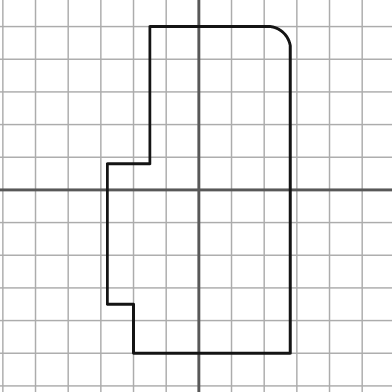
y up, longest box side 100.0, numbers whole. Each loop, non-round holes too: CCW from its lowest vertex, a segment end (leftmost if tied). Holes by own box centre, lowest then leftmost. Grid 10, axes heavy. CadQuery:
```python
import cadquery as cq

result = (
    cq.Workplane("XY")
    .moveTo(-20.0, -50.0)
    .lineTo(28.0, -50.0)
    .lineTo(28.0, 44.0)
    .threePointArc((26.0, 48.0), (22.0, 50.0))
    .lineTo(-15.0, 50.0)
    .lineTo(-15.0, 8.0)
    .lineTo(-28.0, 8.0)
    .lineTo(-28.0, -35.0)
    .lineTo(-20.0, -35.0)
    .close()
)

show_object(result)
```